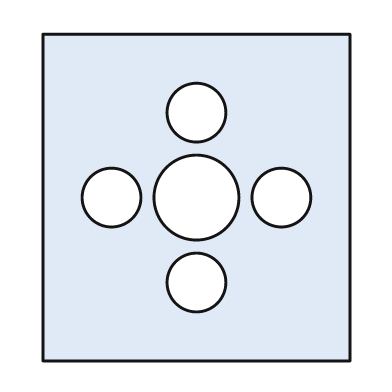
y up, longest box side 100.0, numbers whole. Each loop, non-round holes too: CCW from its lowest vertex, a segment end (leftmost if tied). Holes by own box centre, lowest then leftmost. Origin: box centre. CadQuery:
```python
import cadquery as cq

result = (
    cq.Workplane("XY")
    .moveTo(-47.0, -50.0)
    .lineTo(47.0, -50.0)
    .lineTo(47.0, 50.0)
    .lineTo(-47.0, 50.0)
    .close()
    .moveTo(0.0, -26.0)
    .circle(9.0)
    .moveTo(-26.0, 0.0)
    .circle(9.0)
    .moveTo(0.0, 0.0)
    .circle(13.0)
    .moveTo(26.0, 0.0)
    .circle(9.0)
    .moveTo(0.0, 26.0)
    .circle(9.0)
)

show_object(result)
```